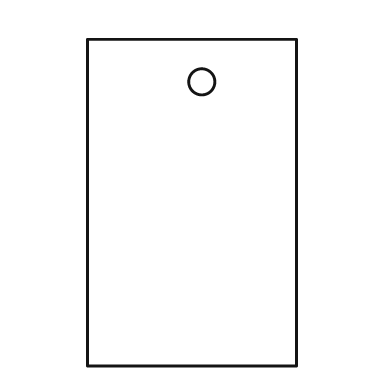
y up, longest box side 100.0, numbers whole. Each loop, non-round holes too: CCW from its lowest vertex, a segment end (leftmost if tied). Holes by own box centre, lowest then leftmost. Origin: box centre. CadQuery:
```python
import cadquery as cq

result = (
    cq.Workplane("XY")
    .moveTo(-32.0, -50.0)
    .lineTo(32.0, -50.0)
    .lineTo(32.0, 50.0)
    .lineTo(-32.0, 50.0)
    .close()
    .moveTo(3.0, 37.0)
    .circle(4.0)
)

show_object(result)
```